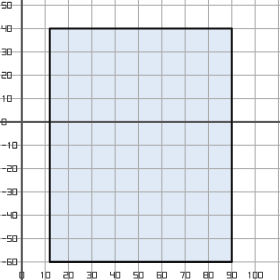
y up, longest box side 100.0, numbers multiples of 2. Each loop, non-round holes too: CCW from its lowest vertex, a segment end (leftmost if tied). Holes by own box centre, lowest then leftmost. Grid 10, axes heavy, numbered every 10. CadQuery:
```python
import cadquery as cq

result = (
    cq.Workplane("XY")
    .moveTo(12.0, -60.0)
    .lineTo(90.0, -60.0)
    .lineTo(90.0, 40.0)
    .lineTo(12.0, 40.0)
    .close()
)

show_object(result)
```